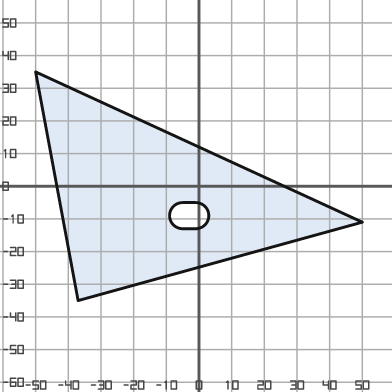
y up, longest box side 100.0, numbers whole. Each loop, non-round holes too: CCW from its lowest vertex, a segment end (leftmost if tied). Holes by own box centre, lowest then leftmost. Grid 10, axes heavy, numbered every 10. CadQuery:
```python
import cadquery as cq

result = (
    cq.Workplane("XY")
    .moveTo(-37.0, -35.0)
    .lineTo(50.0, -11.0)
    .lineTo(-50.0, 35.0)
    .close()
    .moveTo(-5.0, -13.0)
    .lineTo(-1.0, -13.0)
    .threePointArc((3.0, -9.0), (-1.0, -5.0))
    .lineTo(-5.0, -5.0)
    .threePointArc((-9.0, -9.0), (-5.0, -13.0))
    .close()
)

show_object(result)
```